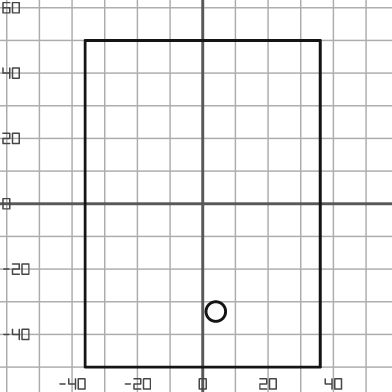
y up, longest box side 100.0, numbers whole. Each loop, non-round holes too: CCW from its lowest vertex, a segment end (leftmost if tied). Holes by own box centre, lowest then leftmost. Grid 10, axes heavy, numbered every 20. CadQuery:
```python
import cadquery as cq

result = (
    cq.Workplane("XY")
    .moveTo(-36.0, -50.0)
    .lineTo(36.0, -50.0)
    .lineTo(36.0, 50.0)
    .lineTo(-36.0, 50.0)
    .close()
    .moveTo(4.0, -33.0)
    .circle(3.0)
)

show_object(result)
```